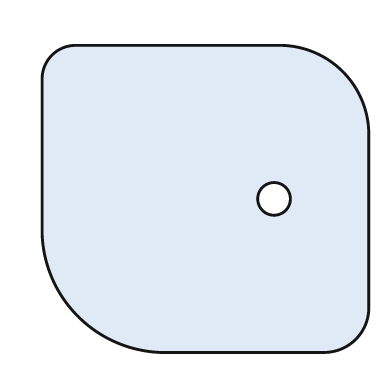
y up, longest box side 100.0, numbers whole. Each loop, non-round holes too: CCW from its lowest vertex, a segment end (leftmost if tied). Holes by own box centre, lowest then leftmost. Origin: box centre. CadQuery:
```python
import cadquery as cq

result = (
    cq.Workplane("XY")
    .moveTo(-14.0, -47.0)
    .lineTo(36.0, -47.0)
    .threePointArc((46.0, -43.0), (50.0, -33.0))
    .lineTo(50.0, 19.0)
    .threePointArc((42.0, 39.0), (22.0, 47.0))
    .lineTo(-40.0, 47.0)
    .threePointArc((-47.0, 44.0), (-50.0, 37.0))
    .lineTo(-50.0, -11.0)
    .threePointArc((-39.0, -36.0), (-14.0, -47.0))
    .close()
    .moveTo(21.0, 0.0)
    .circle(5.0)
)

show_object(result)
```